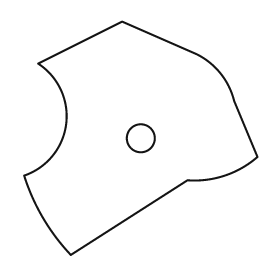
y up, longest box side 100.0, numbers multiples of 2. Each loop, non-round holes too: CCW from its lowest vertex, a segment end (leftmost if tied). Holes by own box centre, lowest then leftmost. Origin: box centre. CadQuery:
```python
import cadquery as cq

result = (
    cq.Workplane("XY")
    .moveTo(-30.0, -50.0)
    .lineTo(20.0, -18.0)
    .threePointArc((36.0, -16.0), (50.0, -8.0))
    .lineTo(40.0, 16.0)
    .threePointArc((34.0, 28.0), (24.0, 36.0))
    .lineTo(-8.0, 50.0)
    .lineTo(-44.0, 32.0)
    .threePointArc((-32.0, 6.0), (-50.0, -16.0))
    .threePointArc((-42.0, -34.0), (-30.0, -50.0))
    .close()
    .moveTo(0.0, 0.0)
    .circle(6.0)
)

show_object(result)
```